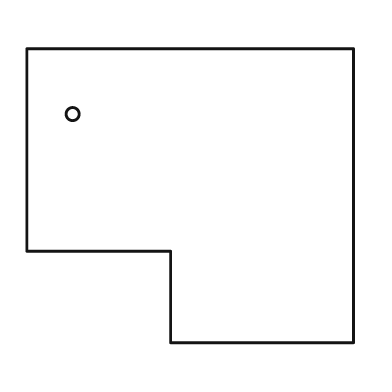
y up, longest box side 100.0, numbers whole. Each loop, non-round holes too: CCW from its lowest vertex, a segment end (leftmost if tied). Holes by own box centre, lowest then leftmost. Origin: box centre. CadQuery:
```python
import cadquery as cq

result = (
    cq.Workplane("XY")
    .moveTo(-6.0, -45.0)
    .lineTo(50.0, -45.0)
    .lineTo(50.0, 45.0)
    .lineTo(-50.0, 45.0)
    .lineTo(-50.0, -17.0)
    .lineTo(-6.0, -17.0)
    .close()
    .moveTo(-36.0, 25.0)
    .circle(2.0)
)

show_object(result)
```